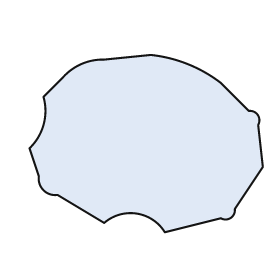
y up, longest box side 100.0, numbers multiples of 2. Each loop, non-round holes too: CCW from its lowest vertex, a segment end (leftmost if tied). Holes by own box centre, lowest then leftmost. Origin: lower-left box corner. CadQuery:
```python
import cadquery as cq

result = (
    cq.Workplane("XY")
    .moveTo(58.0, 0.0)
    .lineTo(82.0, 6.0)
    .threePointArc((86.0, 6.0), (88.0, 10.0))
    .lineTo(100.0, 28.0)
    .lineTo(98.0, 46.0)
    .threePointArc((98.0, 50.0), (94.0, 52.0))
    .lineTo(82.0, 64.0)
    .threePointArc((68.0, 72.0), (52.0, 76.0))
    .lineTo(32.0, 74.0)
    .threePointArc((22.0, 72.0), (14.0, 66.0))
    .lineTo(6.0, 58.0)
    .threePointArc((6.0, 46.0), (0.0, 36.0))
    .lineTo(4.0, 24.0)
    .threePointArc((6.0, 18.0), (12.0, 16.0))
    .lineTo(32.0, 4.0)
    .threePointArc((46.0, 8.0), (58.0, 0.0))
    .close()
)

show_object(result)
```